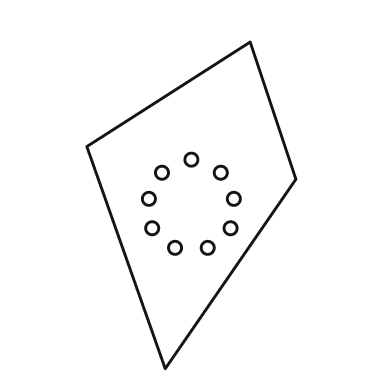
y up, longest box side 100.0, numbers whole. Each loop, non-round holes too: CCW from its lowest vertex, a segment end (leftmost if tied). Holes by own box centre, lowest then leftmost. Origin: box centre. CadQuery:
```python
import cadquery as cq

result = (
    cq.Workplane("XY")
    .moveTo(-8.0, -50.0)
    .lineTo(32.0, 8.0)
    .lineTo(18.0, 50.0)
    .lineTo(-32.0, 18.0)
    .close()
    .moveTo(-5.0, -13.0)
    .circle(2.0)
    .moveTo(5.0, -13.0)
    .circle(2.0)
    .moveTo(-12.0, -7.0)
    .circle(2.0)
    .moveTo(12.0, -7.0)
    .circle(2.0)
    .moveTo(-13.0, 2.0)
    .circle(2.0)
    .moveTo(13.0, 2.0)
    .circle(2.0)
    .moveTo(-9.0, 10.0)
    .circle(2.0)
    .moveTo(9.0, 10.0)
    .circle(2.0)
    .moveTo(0.0, 14.0)
    .circle(2.0)
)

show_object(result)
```